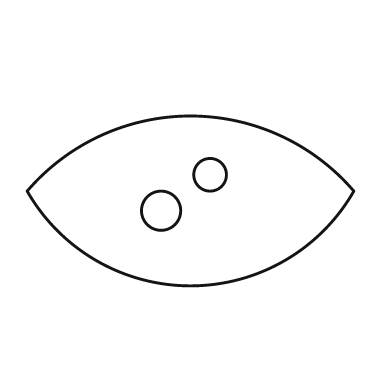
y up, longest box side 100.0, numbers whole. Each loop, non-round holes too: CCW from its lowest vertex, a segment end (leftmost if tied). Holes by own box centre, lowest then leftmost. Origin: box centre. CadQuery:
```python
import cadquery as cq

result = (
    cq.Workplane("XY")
    .moveTo(-50.0, 3.0)
    .threePointArc((0.0, -26.0), (50.0, 3.0))
    .threePointArc((0.0, 26.0), (-50.0, 3.0))
    .close()
    .moveTo(-9.0, -3.0)
    .circle(6.0)
    .moveTo(6.0, 8.0)
    .circle(5.0)
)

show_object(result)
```